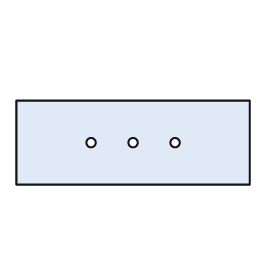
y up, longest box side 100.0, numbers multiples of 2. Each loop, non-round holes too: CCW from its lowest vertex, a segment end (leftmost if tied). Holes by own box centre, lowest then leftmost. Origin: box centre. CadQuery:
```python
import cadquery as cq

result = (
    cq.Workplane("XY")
    .moveTo(-50.0, -18.0)
    .lineTo(50.0, -18.0)
    .lineTo(50.0, 18.0)
    .lineTo(-50.0, 18.0)
    .close()
    .moveTo(-18.0, 0.0)
    .circle(2.0)
    .moveTo(0.0, 0.0)
    .circle(2.0)
    .moveTo(18.0, 0.0)
    .circle(2.0)
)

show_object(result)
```